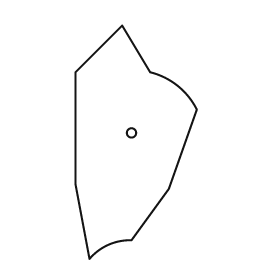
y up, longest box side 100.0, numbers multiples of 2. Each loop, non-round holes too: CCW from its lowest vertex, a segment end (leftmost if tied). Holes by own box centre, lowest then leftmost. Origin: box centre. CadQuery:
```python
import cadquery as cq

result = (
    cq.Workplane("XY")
    .moveTo(-20.0, -50.0)
    .threePointArc((-12.0, -44.0), (-2.0, -42.0))
    .lineTo(14.0, -20.0)
    .lineTo(26.0, 14.0)
    .threePointArc((18.0, 24.0), (6.0, 30.0))
    .lineTo(-6.0, 50.0)
    .lineTo(-26.0, 30.0)
    .lineTo(-26.0, -18.0)
    .close()
    .moveTo(-2.0, 4.0)
    .circle(2.0)
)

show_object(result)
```